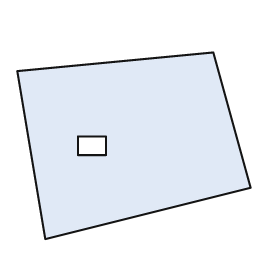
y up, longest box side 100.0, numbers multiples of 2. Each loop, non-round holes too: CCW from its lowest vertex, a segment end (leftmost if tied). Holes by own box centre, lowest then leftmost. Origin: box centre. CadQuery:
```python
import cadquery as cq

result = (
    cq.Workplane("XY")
    .moveTo(-38.0, -40.0)
    .lineTo(50.0, -18.0)
    .lineTo(34.0, 40.0)
    .lineTo(-50.0, 32.0)
    .close()
    .moveTo(-24.0, -4.0)
    .lineTo(-12.0, -4.0)
    .lineTo(-12.0, 4.0)
    .lineTo(-24.0, 4.0)
    .close()
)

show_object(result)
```